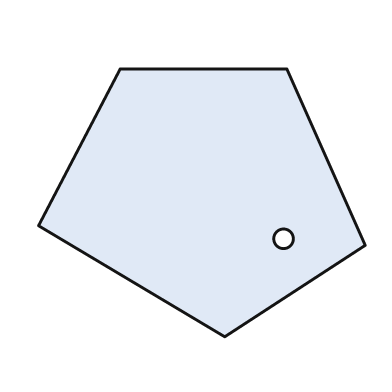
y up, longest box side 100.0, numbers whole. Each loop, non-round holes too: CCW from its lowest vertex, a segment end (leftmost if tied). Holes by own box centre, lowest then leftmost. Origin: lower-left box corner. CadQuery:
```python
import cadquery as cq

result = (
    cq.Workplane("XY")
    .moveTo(57.0, 0.0)
    .lineTo(100.0, 28.0)
    .lineTo(76.0, 82.0)
    .lineTo(25.0, 82.0)
    .lineTo(0.0, 34.0)
    .close()
    .moveTo(75.0, 30.0)
    .circle(3.0)
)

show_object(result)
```